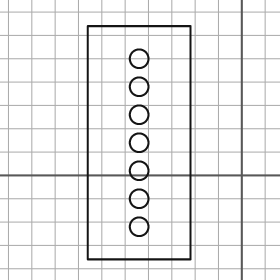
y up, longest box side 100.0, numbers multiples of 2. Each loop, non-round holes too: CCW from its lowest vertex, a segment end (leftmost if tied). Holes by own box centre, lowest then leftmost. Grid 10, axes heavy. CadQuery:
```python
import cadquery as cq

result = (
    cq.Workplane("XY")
    .moveTo(-66.0, -36.0)
    .lineTo(-22.0, -36.0)
    .lineTo(-22.0, 64.0)
    .lineTo(-66.0, 64.0)
    .close()
    .moveTo(-44.0, -22.0)
    .circle(4.0)
    .moveTo(-44.0, -10.0)
    .circle(4.0)
    .moveTo(-44.0, 2.0)
    .circle(4.0)
    .moveTo(-44.0, 14.0)
    .circle(4.0)
    .moveTo(-44.0, 26.0)
    .circle(4.0)
    .moveTo(-44.0, 38.0)
    .circle(4.0)
    .moveTo(-44.0, 50.0)
    .circle(4.0)
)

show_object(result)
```